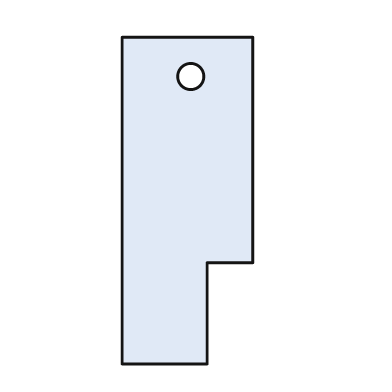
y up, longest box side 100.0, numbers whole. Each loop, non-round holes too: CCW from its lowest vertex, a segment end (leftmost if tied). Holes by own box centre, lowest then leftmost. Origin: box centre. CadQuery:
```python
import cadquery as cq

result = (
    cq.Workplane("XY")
    .moveTo(-20.0, -50.0)
    .lineTo(6.0, -50.0)
    .lineTo(6.0, -19.0)
    .lineTo(20.0, -19.0)
    .lineTo(20.0, 50.0)
    .lineTo(-20.0, 50.0)
    .close()
    .moveTo(1.0, 38.0)
    .circle(4.0)
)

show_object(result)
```